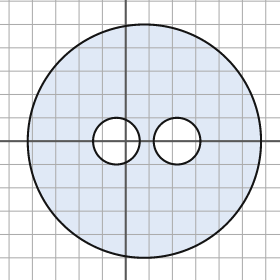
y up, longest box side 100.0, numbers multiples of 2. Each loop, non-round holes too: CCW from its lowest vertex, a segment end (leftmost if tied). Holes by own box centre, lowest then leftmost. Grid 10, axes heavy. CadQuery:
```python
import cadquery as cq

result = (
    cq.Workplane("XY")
    .moveTo(8.0, 0.0)
    .circle(50.0)
    .moveTo(-4.0, 0.0)
    .circle(10.0)
    .moveTo(22.0, 0.0)
    .circle(10.0)
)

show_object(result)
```